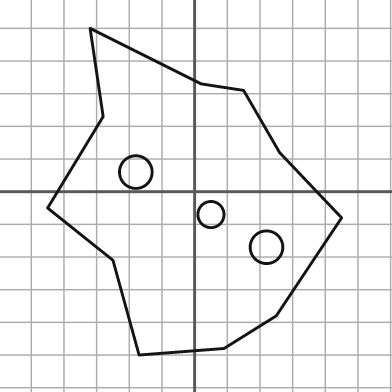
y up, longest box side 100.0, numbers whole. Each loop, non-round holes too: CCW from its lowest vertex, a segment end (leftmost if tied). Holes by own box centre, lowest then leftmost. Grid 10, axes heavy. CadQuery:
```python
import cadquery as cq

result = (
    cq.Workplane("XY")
    .moveTo(-17.0, -50.0)
    .lineTo(9.0, -48.0)
    .lineTo(25.0, -38.0)
    .lineTo(45.0, -8.0)
    .lineTo(26.0, 12.0)
    .lineTo(15.0, 31.0)
    .lineTo(2.0, 33.0)
    .lineTo(-32.0, 50.0)
    .lineTo(-28.0, 23.0)
    .lineTo(-45.0, -5.0)
    .lineTo(-25.0, -21.0)
    .close()
    .moveTo(22.0, -17.0)
    .circle(5.0)
    .moveTo(5.0, -7.0)
    .circle(4.0)
    .moveTo(-18.0, 6.0)
    .circle(5.0)
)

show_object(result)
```